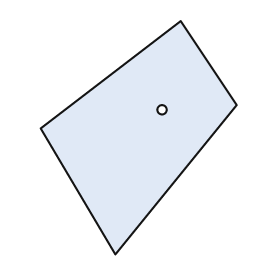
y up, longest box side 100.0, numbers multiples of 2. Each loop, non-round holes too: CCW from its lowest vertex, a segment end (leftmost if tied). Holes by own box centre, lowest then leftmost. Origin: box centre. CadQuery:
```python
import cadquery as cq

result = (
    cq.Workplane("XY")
    .moveTo(-10.0, -50.0)
    .lineTo(42.0, 14.0)
    .lineTo(18.0, 50.0)
    .lineTo(-42.0, 4.0)
    .close()
    .moveTo(10.0, 12.0)
    .circle(2.0)
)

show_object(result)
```